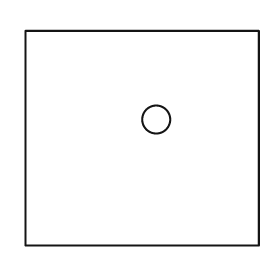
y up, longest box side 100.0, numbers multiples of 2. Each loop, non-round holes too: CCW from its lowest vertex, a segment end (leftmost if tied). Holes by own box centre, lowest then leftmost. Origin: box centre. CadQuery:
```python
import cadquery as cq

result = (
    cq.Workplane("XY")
    .moveTo(-50.0, -46.0)
    .lineTo(50.0, -46.0)
    .lineTo(50.0, 46.0)
    .lineTo(-50.0, 46.0)
    .close()
    .moveTo(6.0, 8.0)
    .circle(6.0)
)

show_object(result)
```